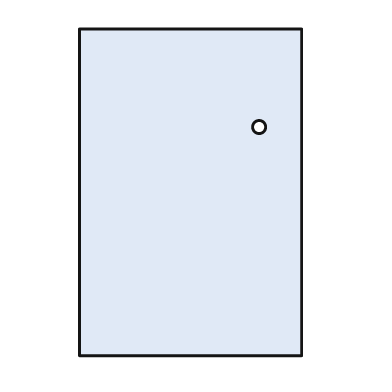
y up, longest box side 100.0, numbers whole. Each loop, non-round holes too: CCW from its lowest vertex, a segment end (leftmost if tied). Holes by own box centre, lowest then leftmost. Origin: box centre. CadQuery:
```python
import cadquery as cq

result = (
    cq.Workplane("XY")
    .moveTo(-34.0, -50.0)
    .lineTo(34.0, -50.0)
    .lineTo(34.0, 50.0)
    .lineTo(-34.0, 50.0)
    .close()
    .moveTo(21.0, 20.0)
    .circle(2.0)
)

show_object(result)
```